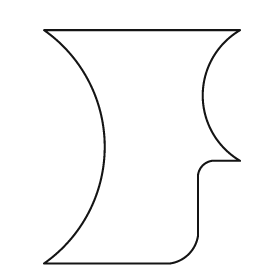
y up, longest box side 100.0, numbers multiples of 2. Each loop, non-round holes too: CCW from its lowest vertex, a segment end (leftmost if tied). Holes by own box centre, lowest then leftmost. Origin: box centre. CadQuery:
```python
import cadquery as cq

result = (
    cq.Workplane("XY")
    .moveTo(-42.0, -50.0)
    .lineTo(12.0, -50.0)
    .threePointArc((20.0, -46.0), (24.0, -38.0))
    .lineTo(24.0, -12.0)
    .threePointArc((26.0, -8.0), (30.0, -6.0))
    .lineTo(42.0, -6.0)
    .threePointArc((26.0, 22.0), (42.0, 50.0))
    .lineTo(-42.0, 50.0)
    .threePointArc((-16.0, 0.0), (-42.0, -50.0))
    .close()
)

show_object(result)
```